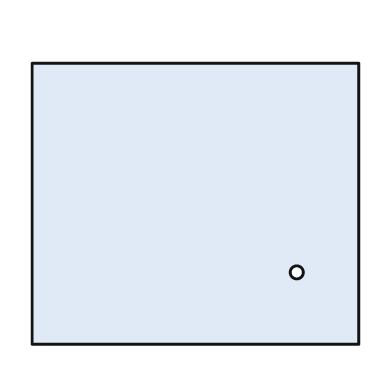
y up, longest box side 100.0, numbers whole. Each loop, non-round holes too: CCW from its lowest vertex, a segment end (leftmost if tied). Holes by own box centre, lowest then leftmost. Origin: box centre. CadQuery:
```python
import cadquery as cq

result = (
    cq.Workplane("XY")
    .moveTo(-50.0, -43.0)
    .lineTo(50.0, -43.0)
    .lineTo(50.0, 43.0)
    .lineTo(-50.0, 43.0)
    .close()
    .moveTo(31.0, -21.0)
    .circle(2.0)
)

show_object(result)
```